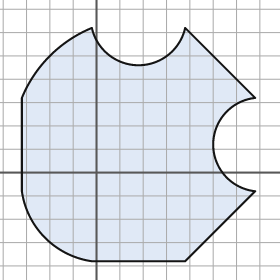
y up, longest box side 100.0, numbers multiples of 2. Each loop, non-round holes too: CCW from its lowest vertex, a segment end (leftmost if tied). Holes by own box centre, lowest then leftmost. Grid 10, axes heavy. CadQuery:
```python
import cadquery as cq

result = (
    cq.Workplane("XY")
    .moveTo(-2.0, -38.0)
    .lineTo(38.0, -38.0)
    .lineTo(68.0, -8.0)
    .threePointArc((50.0, 12.0), (68.0, 32.0))
    .lineTo(38.0, 62.0)
    .threePointArc((18.0, 46.0), (-2.0, 62.0))
    .threePointArc((-20.0, 50.0), (-32.0, 32.0))
    .lineTo(-32.0, -8.0)
    .threePointArc((-22.0, -28.0), (-2.0, -38.0))
    .close()
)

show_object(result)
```